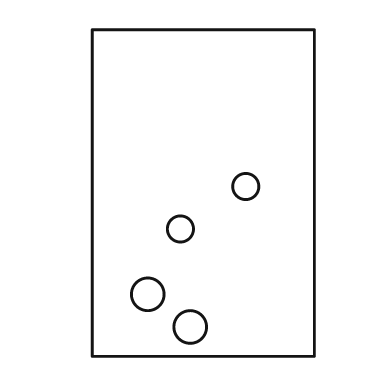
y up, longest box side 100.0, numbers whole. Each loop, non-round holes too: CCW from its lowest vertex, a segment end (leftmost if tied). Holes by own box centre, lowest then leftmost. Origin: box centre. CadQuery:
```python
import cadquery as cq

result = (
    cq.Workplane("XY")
    .moveTo(-34.0, -50.0)
    .lineTo(34.0, -50.0)
    .lineTo(34.0, 50.0)
    .lineTo(-34.0, 50.0)
    .close()
    .moveTo(-4.0, -41.0)
    .circle(5.0)
    .moveTo(-17.0, -31.0)
    .circle(5.0)
    .moveTo(-7.0, -11.0)
    .circle(4.0)
    .moveTo(13.0, 2.0)
    .circle(4.0)
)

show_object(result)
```